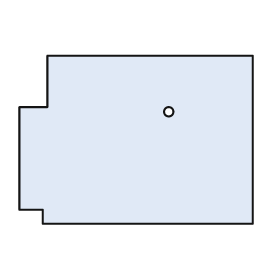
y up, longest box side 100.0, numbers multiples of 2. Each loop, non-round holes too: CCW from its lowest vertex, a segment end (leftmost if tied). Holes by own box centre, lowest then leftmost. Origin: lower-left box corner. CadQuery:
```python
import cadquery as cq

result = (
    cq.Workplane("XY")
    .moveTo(10.0, 0.0)
    .lineTo(100.0, 0.0)
    .lineTo(100.0, 72.0)
    .lineTo(12.0, 72.0)
    .lineTo(12.0, 50.0)
    .lineTo(0.0, 50.0)
    .lineTo(0.0, 6.0)
    .lineTo(10.0, 6.0)
    .close()
    .moveTo(64.0, 48.0)
    .circle(2.0)
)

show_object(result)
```